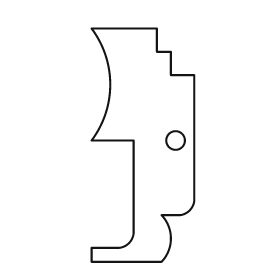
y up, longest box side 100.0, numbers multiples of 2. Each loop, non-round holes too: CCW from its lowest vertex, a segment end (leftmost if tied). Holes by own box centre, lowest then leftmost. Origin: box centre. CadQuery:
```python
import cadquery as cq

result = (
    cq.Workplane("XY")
    .moveTo(-22.0, -50.0)
    .lineTo(8.0, -50.0)
    .threePointArc((12.0, -40.0), (8.0, -30.0))
    .lineTo(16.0, -30.0)
    .threePointArc((20.0, -28.0), (22.0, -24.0))
    .lineTo(22.0, 30.0)
    .lineTo(12.0, 30.0)
    .lineTo(12.0, 40.0)
    .lineTo(6.0, 40.0)
    .lineTo(6.0, 50.0)
    .lineTo(-22.0, 50.0)
    .threePointArc((-14.0, 26.0), (-22.0, 2.0))
    .lineTo(-4.0, 2.0)
    .lineTo(-4.0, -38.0)
    .threePointArc((-6.0, -42.0), (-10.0, -44.0))
    .lineTo(-22.0, -44.0)
    .close()
    .moveTo(14.0, 2.0)
    .circle(4.0)
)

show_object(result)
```